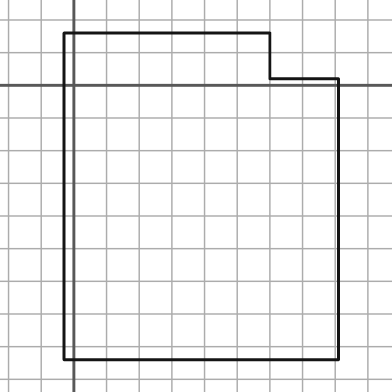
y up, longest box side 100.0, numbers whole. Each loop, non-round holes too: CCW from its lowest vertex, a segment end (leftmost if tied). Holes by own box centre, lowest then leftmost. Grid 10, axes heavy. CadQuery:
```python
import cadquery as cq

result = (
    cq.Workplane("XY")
    .moveTo(-3.0, -84.0)
    .lineTo(81.0, -84.0)
    .lineTo(81.0, 2.0)
    .lineTo(60.0, 2.0)
    .lineTo(60.0, 16.0)
    .lineTo(-3.0, 16.0)
    .close()
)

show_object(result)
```